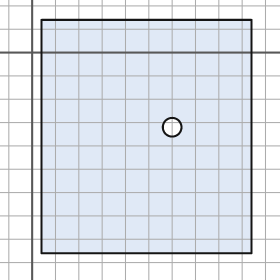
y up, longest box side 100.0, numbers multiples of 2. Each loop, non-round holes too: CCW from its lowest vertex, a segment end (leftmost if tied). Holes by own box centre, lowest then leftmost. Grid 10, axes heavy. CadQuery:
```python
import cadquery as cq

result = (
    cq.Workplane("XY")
    .moveTo(4.0, -86.0)
    .lineTo(94.0, -86.0)
    .lineTo(94.0, 14.0)
    .lineTo(4.0, 14.0)
    .close()
    .moveTo(60.0, -32.0)
    .circle(4.0)
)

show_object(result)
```